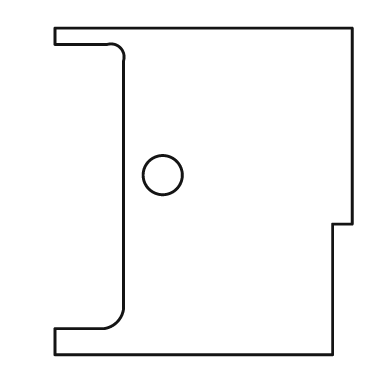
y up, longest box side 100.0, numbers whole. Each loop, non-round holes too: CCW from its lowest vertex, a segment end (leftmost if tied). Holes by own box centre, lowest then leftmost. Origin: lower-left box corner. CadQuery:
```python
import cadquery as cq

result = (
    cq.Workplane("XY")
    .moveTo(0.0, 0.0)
    .lineTo(85.0, 0.0)
    .lineTo(85.0, 40.0)
    .lineTo(91.0, 40.0)
    .lineTo(91.0, 100.0)
    .lineTo(0.0, 100.0)
    .lineTo(0.0, 95.0)
    .lineTo(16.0, 95.0)
    .threePointArc((20.0, 94.0), (21.0, 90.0))
    .lineTo(21.0, 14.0)
    .threePointArc((19.0, 10.0), (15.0, 8.0))
    .lineTo(0.0, 8.0)
    .close()
    .moveTo(33.0, 55.0)
    .circle(6.0)
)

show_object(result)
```